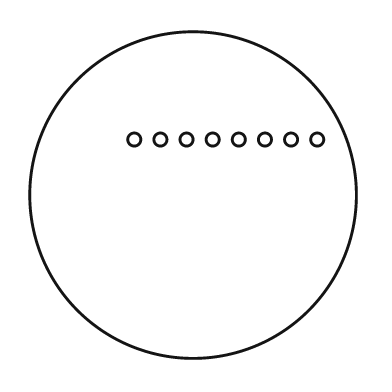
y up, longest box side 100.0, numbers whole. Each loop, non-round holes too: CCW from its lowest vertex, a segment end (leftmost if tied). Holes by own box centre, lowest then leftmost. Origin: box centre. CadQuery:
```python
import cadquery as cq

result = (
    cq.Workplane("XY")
    .moveTo(0.0, 0.0)
    .circle(50.0)
    .moveTo(-18.0, 17.0)
    .circle(2.0)
    .moveTo(-10.0, 17.0)
    .circle(2.0)
    .moveTo(-2.0, 17.0)
    .circle(2.0)
    .moveTo(6.0, 17.0)
    .circle(2.0)
    .moveTo(14.0, 17.0)
    .circle(2.0)
    .moveTo(22.0, 17.0)
    .circle(2.0)
    .moveTo(30.0, 17.0)
    .circle(2.0)
    .moveTo(38.0, 17.0)
    .circle(2.0)
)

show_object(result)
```